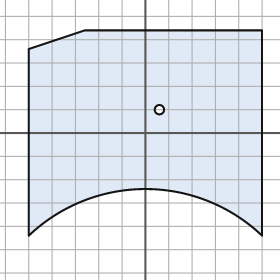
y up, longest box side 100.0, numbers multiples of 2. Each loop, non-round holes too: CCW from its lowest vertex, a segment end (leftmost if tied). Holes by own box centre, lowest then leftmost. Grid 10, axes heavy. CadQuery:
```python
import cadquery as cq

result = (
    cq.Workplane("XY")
    .moveTo(-50.0, -44.0)
    .threePointArc((0.0, -24.0), (50.0, -44.0))
    .lineTo(50.0, 44.0)
    .lineTo(-26.0, 44.0)
    .lineTo(-50.0, 36.0)
    .close()
    .moveTo(6.0, 10.0)
    .circle(2.0)
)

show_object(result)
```